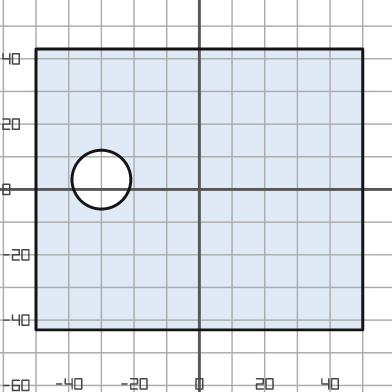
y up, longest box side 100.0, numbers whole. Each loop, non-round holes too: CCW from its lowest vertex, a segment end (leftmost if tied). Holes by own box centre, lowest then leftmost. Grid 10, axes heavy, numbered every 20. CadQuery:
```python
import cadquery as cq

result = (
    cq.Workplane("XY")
    .moveTo(-50.0, -43.0)
    .lineTo(50.0, -43.0)
    .lineTo(50.0, 43.0)
    .lineTo(-50.0, 43.0)
    .close()
    .moveTo(-30.0, 3.0)
    .circle(9.0)
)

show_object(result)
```